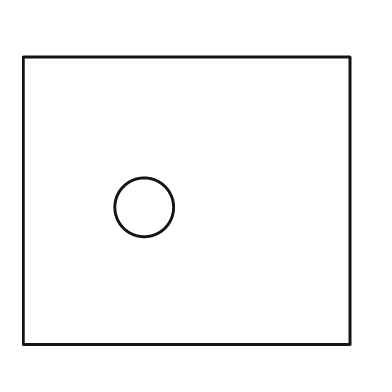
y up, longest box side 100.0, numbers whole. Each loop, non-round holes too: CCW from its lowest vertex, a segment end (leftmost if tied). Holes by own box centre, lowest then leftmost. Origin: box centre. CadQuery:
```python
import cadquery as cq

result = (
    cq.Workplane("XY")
    .moveTo(-50.0, -44.0)
    .lineTo(50.0, -44.0)
    .lineTo(50.0, 44.0)
    .lineTo(-50.0, 44.0)
    .close()
    .moveTo(-13.0, -2.0)
    .circle(9.0)
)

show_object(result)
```